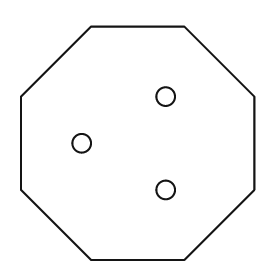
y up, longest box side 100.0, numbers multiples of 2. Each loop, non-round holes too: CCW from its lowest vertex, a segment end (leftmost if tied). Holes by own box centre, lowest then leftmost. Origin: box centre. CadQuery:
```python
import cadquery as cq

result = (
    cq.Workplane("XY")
    .moveTo(-20.0, -50.0)
    .lineTo(20.0, -50.0)
    .lineTo(50.0, -20.0)
    .lineTo(50.0, 20.0)
    .lineTo(20.0, 50.0)
    .lineTo(-20.0, 50.0)
    .lineTo(-50.0, 20.0)
    .lineTo(-50.0, -20.0)
    .close()
    .moveTo(12.0, -20.0)
    .circle(4.0)
    .moveTo(-24.0, 0.0)
    .circle(4.0)
    .moveTo(12.0, 20.0)
    .circle(4.0)
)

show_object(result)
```